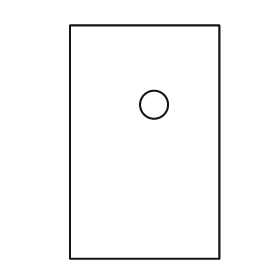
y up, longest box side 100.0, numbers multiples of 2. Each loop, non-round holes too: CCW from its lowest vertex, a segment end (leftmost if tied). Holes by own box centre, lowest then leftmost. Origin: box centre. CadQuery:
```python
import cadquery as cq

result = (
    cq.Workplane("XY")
    .moveTo(-32.0, -50.0)
    .lineTo(32.0, -50.0)
    .lineTo(32.0, 50.0)
    .lineTo(-32.0, 50.0)
    .close()
    .moveTo(4.0, 16.0)
    .circle(6.0)
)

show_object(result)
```